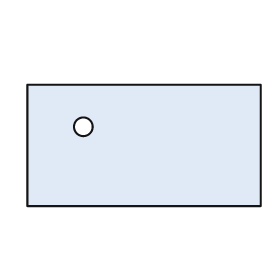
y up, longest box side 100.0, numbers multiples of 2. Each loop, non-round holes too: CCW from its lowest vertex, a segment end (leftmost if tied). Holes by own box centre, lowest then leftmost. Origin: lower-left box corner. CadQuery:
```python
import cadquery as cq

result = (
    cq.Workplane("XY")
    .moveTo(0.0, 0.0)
    .lineTo(100.0, 0.0)
    .lineTo(100.0, 52.0)
    .lineTo(0.0, 52.0)
    .close()
    .moveTo(24.0, 34.0)
    .circle(4.0)
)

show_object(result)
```